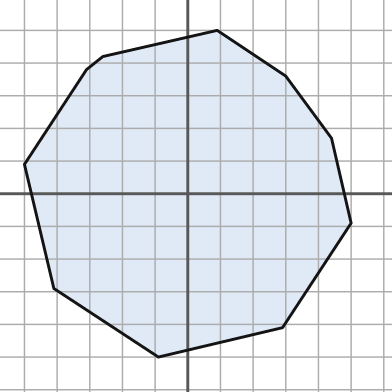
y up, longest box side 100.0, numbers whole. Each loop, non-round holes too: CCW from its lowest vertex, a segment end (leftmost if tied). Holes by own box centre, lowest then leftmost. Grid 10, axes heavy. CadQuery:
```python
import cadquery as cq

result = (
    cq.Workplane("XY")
    .moveTo(-9.0, -50.0)
    .lineTo(29.0, -41.0)
    .lineTo(50.0, -9.0)
    .lineTo(44.0, 17.0)
    .lineTo(30.0, 36.0)
    .lineTo(9.0, 50.0)
    .lineTo(-26.0, 42.0)
    .lineTo(-31.0, 38.0)
    .lineTo(-50.0, 9.0)
    .lineTo(-41.0, -29.0)
    .close()
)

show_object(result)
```